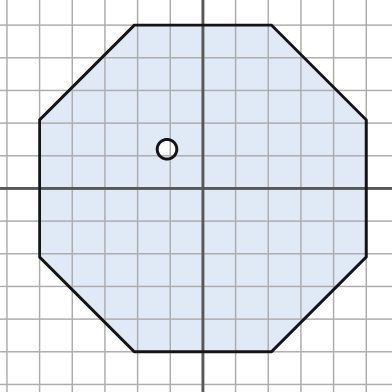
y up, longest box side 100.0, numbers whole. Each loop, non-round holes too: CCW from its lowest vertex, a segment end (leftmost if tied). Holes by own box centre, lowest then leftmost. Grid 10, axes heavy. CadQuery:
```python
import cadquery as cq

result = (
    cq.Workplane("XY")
    .moveTo(-21.0, -50.0)
    .lineTo(21.0, -50.0)
    .lineTo(50.0, -21.0)
    .lineTo(50.0, 21.0)
    .lineTo(21.0, 50.0)
    .lineTo(-21.0, 50.0)
    .lineTo(-50.0, 21.0)
    .lineTo(-50.0, -21.0)
    .close()
    .moveTo(-11.0, 12.0)
    .circle(3.0)
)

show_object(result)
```